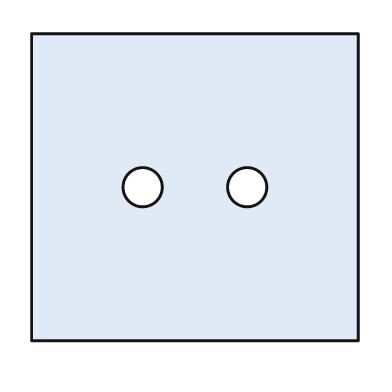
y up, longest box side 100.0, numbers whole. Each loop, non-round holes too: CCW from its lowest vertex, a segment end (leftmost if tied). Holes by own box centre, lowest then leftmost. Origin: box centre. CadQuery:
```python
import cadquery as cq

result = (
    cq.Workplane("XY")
    .moveTo(-50.0, -47.0)
    .lineTo(50.0, -47.0)
    .lineTo(50.0, 47.0)
    .lineTo(-50.0, 47.0)
    .close()
    .moveTo(-16.0, 0.0)
    .circle(6.0)
    .moveTo(16.0, 0.0)
    .circle(6.0)
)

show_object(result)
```